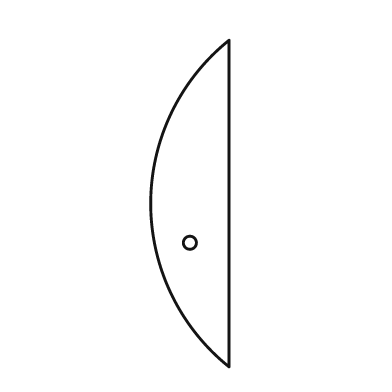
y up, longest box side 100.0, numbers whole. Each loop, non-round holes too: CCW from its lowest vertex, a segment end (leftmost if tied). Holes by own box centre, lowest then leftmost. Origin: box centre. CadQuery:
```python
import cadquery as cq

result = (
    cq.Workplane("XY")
    .moveTo(12.0, -50.0)
    .lineTo(12.0, 50.0)
    .threePointArc((-12.0, 0.0), (12.0, -50.0))
    .close()
    .moveTo(0.0, -12.0)
    .circle(2.0)
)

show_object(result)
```